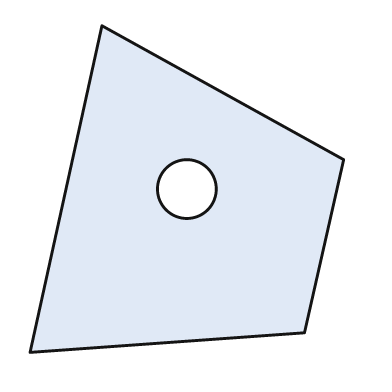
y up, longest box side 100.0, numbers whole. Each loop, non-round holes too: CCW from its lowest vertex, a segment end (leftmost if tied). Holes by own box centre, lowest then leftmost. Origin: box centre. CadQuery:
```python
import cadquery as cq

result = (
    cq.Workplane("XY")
    .moveTo(-48.0, -50.0)
    .lineTo(36.0, -44.0)
    .lineTo(48.0, 9.0)
    .lineTo(-26.0, 50.0)
    .close()
    .moveTo(0.0, 0.0)
    .circle(9.0)
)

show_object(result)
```